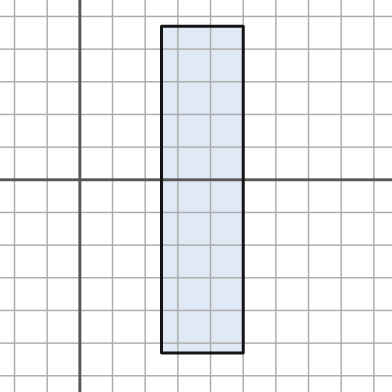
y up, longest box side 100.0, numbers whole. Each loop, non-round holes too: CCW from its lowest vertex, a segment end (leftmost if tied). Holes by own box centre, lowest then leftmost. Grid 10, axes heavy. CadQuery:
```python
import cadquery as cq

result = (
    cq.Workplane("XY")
    .moveTo(25.0, -53.0)
    .lineTo(50.0, -53.0)
    .lineTo(50.0, 47.0)
    .lineTo(25.0, 47.0)
    .close()
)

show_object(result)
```